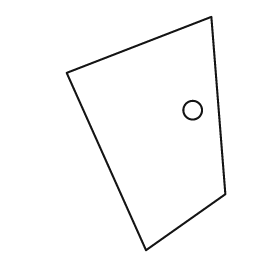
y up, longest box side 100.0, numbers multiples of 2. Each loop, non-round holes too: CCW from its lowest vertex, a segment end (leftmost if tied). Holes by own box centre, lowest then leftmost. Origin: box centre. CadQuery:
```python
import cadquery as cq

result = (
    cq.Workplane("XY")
    .moveTo(0.0, -50.0)
    .lineTo(34.0, -26.0)
    .lineTo(28.0, 50.0)
    .lineTo(-34.0, 26.0)
    .close()
    .moveTo(20.0, 10.0)
    .circle(4.0)
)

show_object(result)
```